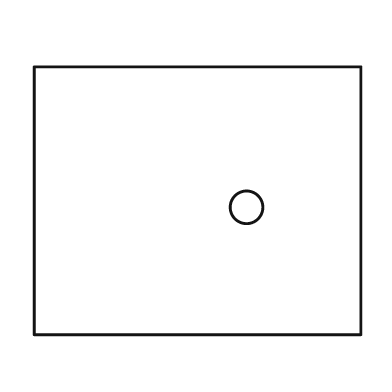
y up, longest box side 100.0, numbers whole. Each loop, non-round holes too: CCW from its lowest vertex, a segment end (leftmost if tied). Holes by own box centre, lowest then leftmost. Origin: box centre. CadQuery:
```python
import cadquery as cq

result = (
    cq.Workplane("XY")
    .moveTo(-50.0, -41.0)
    .lineTo(50.0, -41.0)
    .lineTo(50.0, 41.0)
    .lineTo(-50.0, 41.0)
    .close()
    .moveTo(15.0, -2.0)
    .circle(5.0)
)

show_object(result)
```